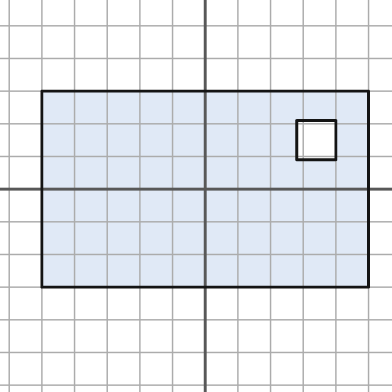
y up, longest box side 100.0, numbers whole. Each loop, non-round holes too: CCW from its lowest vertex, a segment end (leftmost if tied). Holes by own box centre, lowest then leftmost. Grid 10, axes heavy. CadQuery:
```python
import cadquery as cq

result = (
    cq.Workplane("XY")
    .moveTo(-50.0, -30.0)
    .lineTo(50.0, -30.0)
    .lineTo(50.0, 30.0)
    .lineTo(-50.0, 30.0)
    .close()
    .moveTo(28.0, 9.0)
    .lineTo(40.0, 9.0)
    .lineTo(40.0, 21.0)
    .lineTo(28.0, 21.0)
    .close()
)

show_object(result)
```